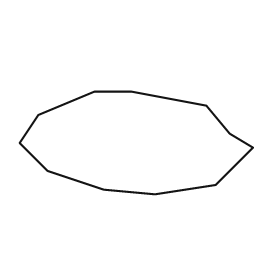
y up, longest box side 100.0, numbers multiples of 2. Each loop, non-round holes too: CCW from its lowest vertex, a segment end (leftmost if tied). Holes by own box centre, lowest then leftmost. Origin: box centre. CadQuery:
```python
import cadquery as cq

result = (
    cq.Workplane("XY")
    .moveTo(8.0, -22.0)
    .lineTo(34.0, -18.0)
    .lineTo(50.0, -2.0)
    .lineTo(40.0, 4.0)
    .lineTo(30.0, 16.0)
    .lineTo(-2.0, 22.0)
    .lineTo(-18.0, 22.0)
    .lineTo(-42.0, 12.0)
    .lineTo(-50.0, 0.0)
    .lineTo(-38.0, -12.0)
    .lineTo(-14.0, -20.0)
    .close()
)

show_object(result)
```